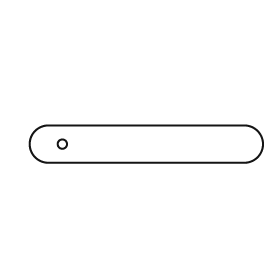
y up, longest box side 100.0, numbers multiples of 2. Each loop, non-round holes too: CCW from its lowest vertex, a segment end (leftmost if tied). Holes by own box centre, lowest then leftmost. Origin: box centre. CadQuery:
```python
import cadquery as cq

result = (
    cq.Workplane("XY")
    .moveTo(-42.0, -8.0)
    .lineTo(42.0, -8.0)
    .threePointArc((50.0, 0.0), (42.0, 8.0))
    .lineTo(-42.0, 8.0)
    .threePointArc((-50.0, 0.0), (-42.0, -8.0))
    .close()
    .moveTo(-36.0, 0.0)
    .circle(2.0)
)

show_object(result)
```